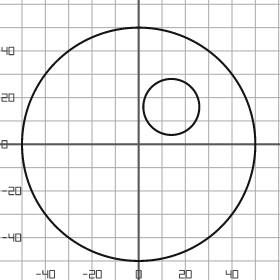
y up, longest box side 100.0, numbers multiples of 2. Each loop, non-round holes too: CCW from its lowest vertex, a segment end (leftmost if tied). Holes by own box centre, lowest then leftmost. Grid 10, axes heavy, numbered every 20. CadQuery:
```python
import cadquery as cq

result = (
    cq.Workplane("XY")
    .moveTo(0.0, 0.0)
    .circle(50.0)
    .moveTo(14.0, 16.0)
    .circle(12.0)
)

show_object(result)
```